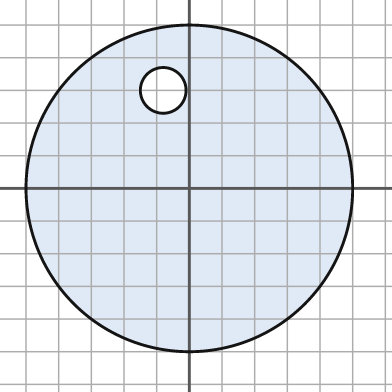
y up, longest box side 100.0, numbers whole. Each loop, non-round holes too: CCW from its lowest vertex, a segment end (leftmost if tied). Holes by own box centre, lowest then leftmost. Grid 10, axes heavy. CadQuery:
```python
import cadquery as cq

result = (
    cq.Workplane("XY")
    .moveTo(0.0, 0.0)
    .circle(50.0)
    .moveTo(-8.0, 30.0)
    .circle(7.0)
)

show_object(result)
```